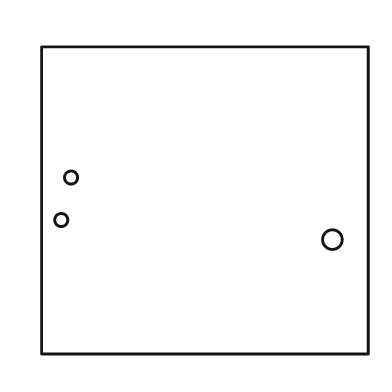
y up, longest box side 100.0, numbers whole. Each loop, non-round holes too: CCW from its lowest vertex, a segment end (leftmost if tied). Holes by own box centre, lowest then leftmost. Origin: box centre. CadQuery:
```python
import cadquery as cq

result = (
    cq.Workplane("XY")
    .moveTo(-50.0, -47.0)
    .lineTo(50.0, -47.0)
    .lineTo(50.0, 47.0)
    .lineTo(-50.0, 47.0)
    .close()
    .moveTo(39.0, -12.0)
    .circle(3.0)
    .moveTo(-44.0, -6.0)
    .circle(2.0)
    .moveTo(-41.0, 7.0)
    .circle(2.0)
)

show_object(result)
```